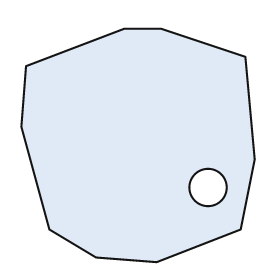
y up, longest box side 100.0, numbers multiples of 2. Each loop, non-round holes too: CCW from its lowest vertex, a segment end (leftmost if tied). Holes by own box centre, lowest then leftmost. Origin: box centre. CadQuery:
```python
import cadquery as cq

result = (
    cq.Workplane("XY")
    .moveTo(8.0, -50.0)
    .lineTo(44.0, -36.0)
    .lineTo(50.0, -6.0)
    .lineTo(46.0, 38.0)
    .lineTo(10.0, 50.0)
    .lineTo(-6.0, 50.0)
    .lineTo(-48.0, 34.0)
    .lineTo(-50.0, 8.0)
    .lineTo(-38.0, -36.0)
    .lineTo(-18.0, -48.0)
    .close()
    .moveTo(30.0, -18.0)
    .circle(8.0)
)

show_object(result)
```